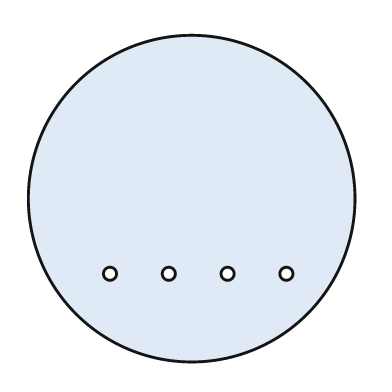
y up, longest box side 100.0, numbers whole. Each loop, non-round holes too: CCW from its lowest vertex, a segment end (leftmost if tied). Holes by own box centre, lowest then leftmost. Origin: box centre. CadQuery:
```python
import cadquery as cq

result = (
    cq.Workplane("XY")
    .moveTo(0.0, 0.0)
    .circle(50.0)
    .moveTo(-25.0, -23.0)
    .circle(2.0)
    .moveTo(-7.0, -23.0)
    .circle(2.0)
    .moveTo(11.0, -23.0)
    .circle(2.0)
    .moveTo(29.0, -23.0)
    .circle(2.0)
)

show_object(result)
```